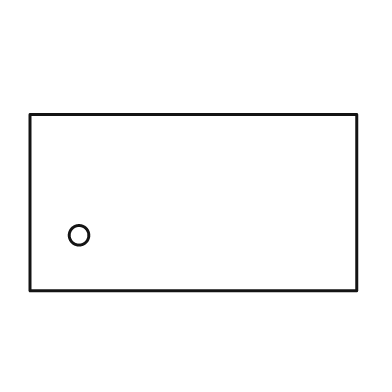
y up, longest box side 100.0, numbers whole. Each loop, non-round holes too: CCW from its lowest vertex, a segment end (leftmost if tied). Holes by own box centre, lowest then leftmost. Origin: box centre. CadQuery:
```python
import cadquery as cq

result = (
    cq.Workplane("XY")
    .moveTo(-50.0, -27.0)
    .lineTo(50.0, -27.0)
    .lineTo(50.0, 27.0)
    .lineTo(-50.0, 27.0)
    .close()
    .moveTo(-35.0, -10.0)
    .circle(3.0)
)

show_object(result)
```